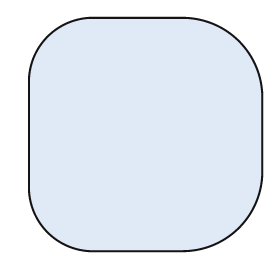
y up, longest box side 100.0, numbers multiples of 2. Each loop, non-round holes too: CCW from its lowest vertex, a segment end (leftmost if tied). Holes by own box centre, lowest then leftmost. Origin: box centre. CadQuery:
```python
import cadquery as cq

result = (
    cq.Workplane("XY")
    .moveTo(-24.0, -50.0)
    .lineTo(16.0, -50.0)
    .threePointArc((40.0, -40.0), (50.0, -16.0))
    .lineTo(50.0, 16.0)
    .threePointArc((40.0, 40.0), (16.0, 50.0))
    .lineTo(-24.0, 50.0)
    .threePointArc((-42.0, 42.0), (-50.0, 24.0))
    .lineTo(-50.0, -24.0)
    .threePointArc((-42.0, -42.0), (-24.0, -50.0))
    .close()
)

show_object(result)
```